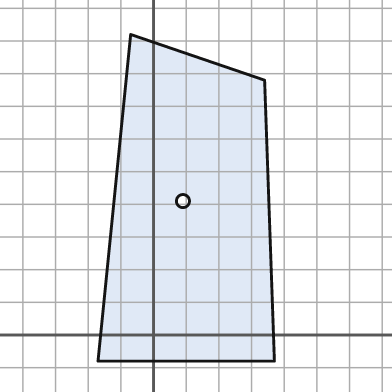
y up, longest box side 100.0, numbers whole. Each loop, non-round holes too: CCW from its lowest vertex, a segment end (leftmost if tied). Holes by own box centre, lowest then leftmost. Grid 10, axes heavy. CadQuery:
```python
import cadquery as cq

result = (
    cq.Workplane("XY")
    .moveTo(-17.0, -8.0)
    .lineTo(37.0, -8.0)
    .lineTo(34.0, 78.0)
    .lineTo(-7.0, 92.0)
    .close()
    .moveTo(9.0, 41.0)
    .circle(2.0)
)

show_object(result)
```